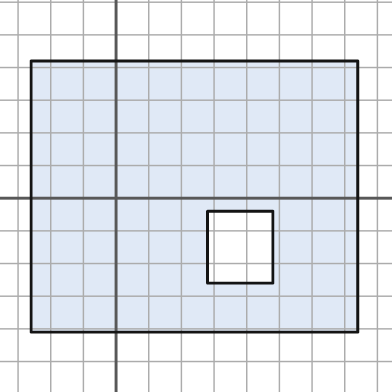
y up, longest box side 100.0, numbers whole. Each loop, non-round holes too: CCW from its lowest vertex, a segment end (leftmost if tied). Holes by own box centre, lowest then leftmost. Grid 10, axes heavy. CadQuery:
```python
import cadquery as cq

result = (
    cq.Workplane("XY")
    .moveTo(-26.0, -41.0)
    .lineTo(74.0, -41.0)
    .lineTo(74.0, 42.0)
    .lineTo(-26.0, 42.0)
    .close()
    .moveTo(28.0, -26.0)
    .lineTo(48.0, -26.0)
    .lineTo(48.0, -4.0)
    .lineTo(28.0, -4.0)
    .close()
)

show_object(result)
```